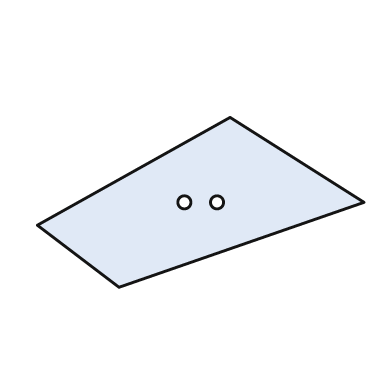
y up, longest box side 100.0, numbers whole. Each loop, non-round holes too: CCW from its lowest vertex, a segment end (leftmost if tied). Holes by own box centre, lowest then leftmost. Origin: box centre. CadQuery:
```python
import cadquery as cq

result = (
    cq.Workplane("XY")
    .moveTo(-25.0, -26.0)
    .lineTo(50.0, 0.0)
    .lineTo(9.0, 26.0)
    .lineTo(-50.0, -7.0)
    .close()
    .moveTo(-5.0, 0.0)
    .circle(2.0)
    .moveTo(5.0, 0.0)
    .circle(2.0)
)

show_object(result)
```